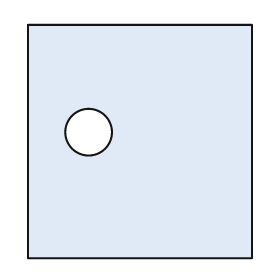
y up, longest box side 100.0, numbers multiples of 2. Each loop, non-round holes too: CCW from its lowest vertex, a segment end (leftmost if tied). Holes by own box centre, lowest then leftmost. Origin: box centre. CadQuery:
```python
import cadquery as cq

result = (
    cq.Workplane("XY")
    .moveTo(-48.0, -50.0)
    .lineTo(48.0, -50.0)
    .lineTo(48.0, 50.0)
    .lineTo(-48.0, 50.0)
    .close()
    .moveTo(-22.0, 4.0)
    .circle(10.0)
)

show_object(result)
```